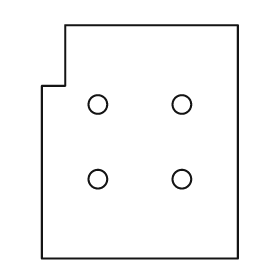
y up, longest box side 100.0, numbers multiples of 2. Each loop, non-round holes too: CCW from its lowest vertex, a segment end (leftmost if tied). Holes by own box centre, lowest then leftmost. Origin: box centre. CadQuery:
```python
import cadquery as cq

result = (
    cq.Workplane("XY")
    .moveTo(-42.0, -50.0)
    .lineTo(42.0, -50.0)
    .lineTo(42.0, 50.0)
    .lineTo(-32.0, 50.0)
    .lineTo(-32.0, 24.0)
    .lineTo(-42.0, 24.0)
    .close()
    .moveTo(-18.0, -16.0)
    .circle(4.0)
    .moveTo(18.0, -16.0)
    .circle(4.0)
    .moveTo(-18.0, 16.0)
    .circle(4.0)
    .moveTo(18.0, 16.0)
    .circle(4.0)
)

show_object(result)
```